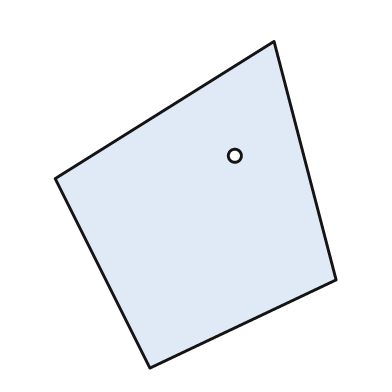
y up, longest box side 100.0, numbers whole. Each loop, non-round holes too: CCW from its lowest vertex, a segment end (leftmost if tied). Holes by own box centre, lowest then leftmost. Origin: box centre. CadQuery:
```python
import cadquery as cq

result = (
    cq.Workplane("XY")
    .moveTo(-14.0, -50.0)
    .lineTo(43.0, -23.0)
    .lineTo(24.0, 50.0)
    .lineTo(-43.0, 8.0)
    .close()
    .moveTo(12.0, 15.0)
    .circle(2.0)
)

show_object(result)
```